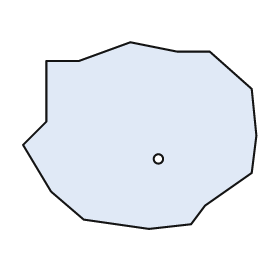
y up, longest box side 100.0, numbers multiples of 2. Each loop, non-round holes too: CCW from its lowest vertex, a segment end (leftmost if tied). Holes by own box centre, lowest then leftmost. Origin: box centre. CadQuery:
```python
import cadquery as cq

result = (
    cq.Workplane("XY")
    .moveTo(4.0, -40.0)
    .lineTo(22.0, -38.0)
    .lineTo(28.0, -30.0)
    .lineTo(48.0, -16.0)
    .lineTo(50.0, 0.0)
    .lineTo(48.0, 20.0)
    .lineTo(30.0, 36.0)
    .lineTo(16.0, 36.0)
    .lineTo(-4.0, 40.0)
    .lineTo(-26.0, 32.0)
    .lineTo(-40.0, 32.0)
    .lineTo(-40.0, 6.0)
    .lineTo(-50.0, -4.0)
    .lineTo(-38.0, -24.0)
    .lineTo(-24.0, -36.0)
    .close()
    .moveTo(8.0, -10.0)
    .circle(2.0)
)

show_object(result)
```